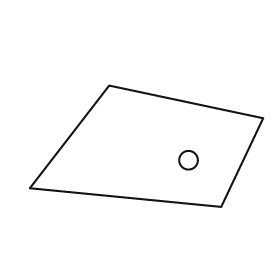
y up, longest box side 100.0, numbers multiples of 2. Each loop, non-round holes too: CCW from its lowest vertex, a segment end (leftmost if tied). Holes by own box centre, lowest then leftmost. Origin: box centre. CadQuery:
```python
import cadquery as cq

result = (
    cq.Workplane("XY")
    .moveTo(32.0, -26.0)
    .lineTo(50.0, 12.0)
    .lineTo(-16.0, 26.0)
    .lineTo(-50.0, -18.0)
    .close()
    .moveTo(18.0, -6.0)
    .circle(4.0)
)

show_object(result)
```